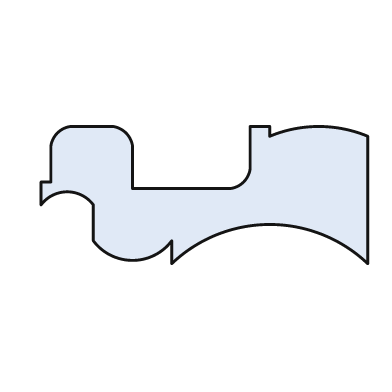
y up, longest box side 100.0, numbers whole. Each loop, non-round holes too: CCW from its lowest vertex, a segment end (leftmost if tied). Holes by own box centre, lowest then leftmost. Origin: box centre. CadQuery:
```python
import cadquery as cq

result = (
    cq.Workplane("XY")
    .moveTo(-10.0, -21.0)
    .threePointArc((20.0, -9.0), (50.0, -21.0))
    .lineTo(50.0, 18.0)
    .threePointArc((35.0, 21.0), (20.0, 18.0))
    .lineTo(20.0, 21.0)
    .lineTo(14.0, 21.0)
    .lineTo(14.0, 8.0)
    .threePointArc((12.0, 4.0), (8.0, 2.0))
    .lineTo(-22.0, 2.0)
    .lineTo(-22.0, 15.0)
    .threePointArc((-24.0, 19.0), (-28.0, 21.0))
    .lineTo(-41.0, 21.0)
    .threePointArc((-45.0, 19.0), (-47.0, 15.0))
    .lineTo(-47.0, 4.0)
    .lineTo(-50.0, 4.0)
    .lineTo(-50.0, -3.0)
    .threePointArc((-42.0, 1.0), (-34.0, -3.0))
    .lineTo(-34.0, -14.0)
    .threePointArc((-22.0, -20.0), (-10.0, -14.0))
    .close()
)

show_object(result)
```